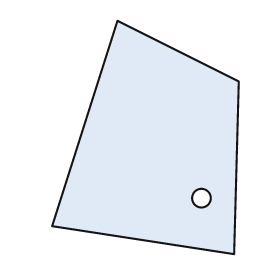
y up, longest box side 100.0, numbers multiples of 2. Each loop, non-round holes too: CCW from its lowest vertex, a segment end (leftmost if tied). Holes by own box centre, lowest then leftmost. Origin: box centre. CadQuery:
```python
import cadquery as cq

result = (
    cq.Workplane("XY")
    .moveTo(38.0, -50.0)
    .lineTo(40.0, 24.0)
    .lineTo(-12.0, 50.0)
    .lineTo(-40.0, -38.0)
    .close()
    .moveTo(24.0, -26.0)
    .circle(4.0)
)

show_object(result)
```